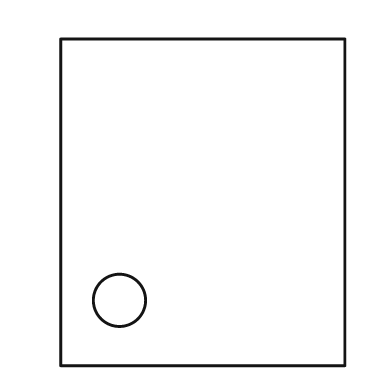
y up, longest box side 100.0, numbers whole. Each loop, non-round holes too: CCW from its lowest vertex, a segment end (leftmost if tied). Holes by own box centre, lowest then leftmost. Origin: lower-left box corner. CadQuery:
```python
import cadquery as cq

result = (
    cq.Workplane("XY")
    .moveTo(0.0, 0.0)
    .lineTo(87.0, 0.0)
    .lineTo(87.0, 100.0)
    .lineTo(0.0, 100.0)
    .close()
    .moveTo(18.0, 20.0)
    .circle(8.0)
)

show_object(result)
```